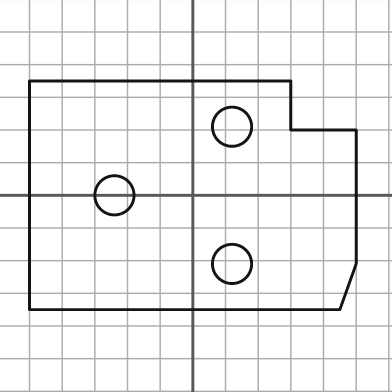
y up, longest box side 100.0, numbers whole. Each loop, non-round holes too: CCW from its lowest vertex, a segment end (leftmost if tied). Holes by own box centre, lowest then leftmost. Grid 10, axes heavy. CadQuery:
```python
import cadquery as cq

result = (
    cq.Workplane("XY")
    .moveTo(-50.0, -35.0)
    .lineTo(45.0, -35.0)
    .lineTo(50.0, -21.0)
    .lineTo(50.0, 20.0)
    .lineTo(30.0, 20.0)
    .lineTo(30.0, 35.0)
    .lineTo(-50.0, 35.0)
    .close()
    .moveTo(12.0, -21.0)
    .circle(6.0)
    .moveTo(-24.0, 0.0)
    .circle(6.0)
    .moveTo(12.0, 21.0)
    .circle(6.0)
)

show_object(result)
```